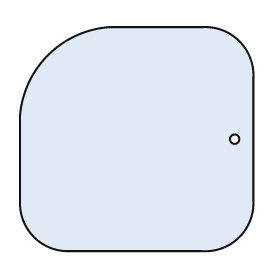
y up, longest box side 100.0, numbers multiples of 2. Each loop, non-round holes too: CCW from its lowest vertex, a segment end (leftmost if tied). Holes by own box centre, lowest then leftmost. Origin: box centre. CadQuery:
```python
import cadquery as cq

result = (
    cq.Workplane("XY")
    .moveTo(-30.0, -48.0)
    .lineTo(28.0, -48.0)
    .threePointArc((44.0, -42.0), (50.0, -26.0))
    .lineTo(50.0, 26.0)
    .threePointArc((44.0, 42.0), (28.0, 48.0))
    .lineTo(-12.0, 48.0)
    .threePointArc((-38.0, 36.0), (-50.0, 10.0))
    .lineTo(-50.0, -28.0)
    .threePointArc((-44.0, -42.0), (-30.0, -48.0))
    .close()
    .moveTo(42.0, 0.0)
    .circle(2.0)
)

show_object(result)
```